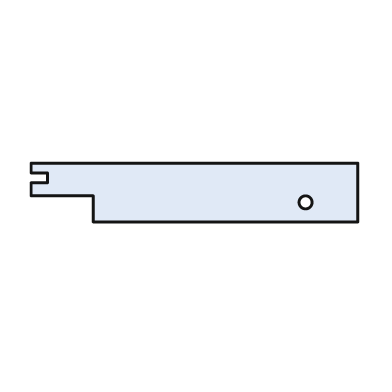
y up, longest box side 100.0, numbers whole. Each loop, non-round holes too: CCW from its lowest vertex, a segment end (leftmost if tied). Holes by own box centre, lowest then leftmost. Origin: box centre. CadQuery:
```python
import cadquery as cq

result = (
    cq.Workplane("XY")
    .moveTo(-31.0, -9.0)
    .lineTo(50.0, -9.0)
    .lineTo(50.0, 9.0)
    .lineTo(-50.0, 9.0)
    .lineTo(-50.0, 6.0)
    .lineTo(-45.0, 6.0)
    .lineTo(-45.0, 3.0)
    .lineTo(-50.0, 3.0)
    .lineTo(-50.0, -1.0)
    .lineTo(-31.0, -1.0)
    .close()
    .moveTo(34.0, -3.0)
    .circle(2.0)
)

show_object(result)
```